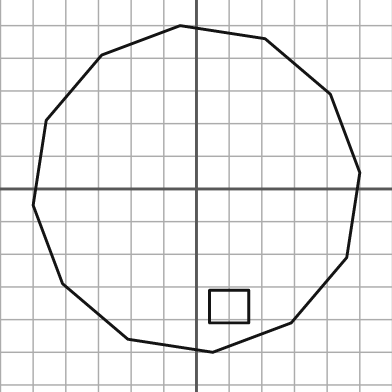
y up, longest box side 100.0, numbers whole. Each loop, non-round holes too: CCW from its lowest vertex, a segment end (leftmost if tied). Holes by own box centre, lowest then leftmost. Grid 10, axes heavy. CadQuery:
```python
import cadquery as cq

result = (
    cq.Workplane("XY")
    .moveTo(5.0, -50.0)
    .lineTo(29.0, -41.0)
    .lineTo(46.0, -21.0)
    .lineTo(50.0, 5.0)
    .lineTo(41.0, 29.0)
    .lineTo(21.0, 46.0)
    .lineTo(-5.0, 50.0)
    .lineTo(-29.0, 41.0)
    .lineTo(-46.0, 21.0)
    .lineTo(-50.0, -5.0)
    .lineTo(-41.0, -29.0)
    .lineTo(-21.0, -46.0)
    .close()
    .moveTo(4.0, -41.0)
    .lineTo(16.0, -41.0)
    .lineTo(16.0, -31.0)
    .lineTo(4.0, -31.0)
    .close()
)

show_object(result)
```